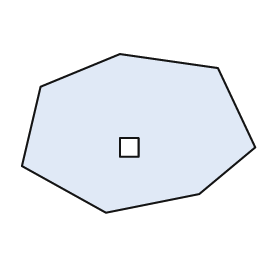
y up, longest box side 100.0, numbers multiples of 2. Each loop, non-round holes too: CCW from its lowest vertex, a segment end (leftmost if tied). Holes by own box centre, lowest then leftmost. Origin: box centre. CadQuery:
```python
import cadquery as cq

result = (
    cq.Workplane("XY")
    .moveTo(-14.0, -34.0)
    .lineTo(26.0, -26.0)
    .lineTo(50.0, -6.0)
    .lineTo(34.0, 28.0)
    .lineTo(-8.0, 34.0)
    .lineTo(-42.0, 20.0)
    .lineTo(-50.0, -14.0)
    .close()
    .moveTo(-8.0, -10.0)
    .lineTo(0.0, -10.0)
    .lineTo(0.0, -2.0)
    .lineTo(-8.0, -2.0)
    .close()
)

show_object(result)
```